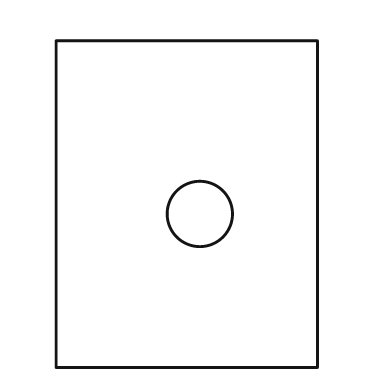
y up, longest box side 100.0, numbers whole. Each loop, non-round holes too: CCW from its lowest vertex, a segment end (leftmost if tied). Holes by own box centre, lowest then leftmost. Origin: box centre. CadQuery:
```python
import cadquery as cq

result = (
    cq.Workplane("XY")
    .moveTo(-40.0, -50.0)
    .lineTo(40.0, -50.0)
    .lineTo(40.0, 50.0)
    .lineTo(-40.0, 50.0)
    .close()
    .moveTo(4.0, -3.0)
    .circle(10.0)
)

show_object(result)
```